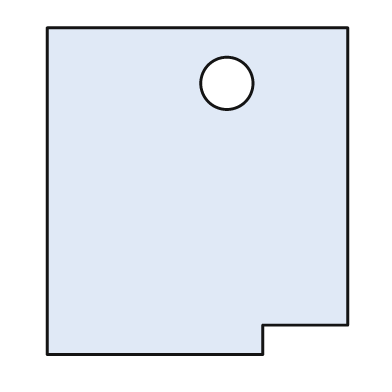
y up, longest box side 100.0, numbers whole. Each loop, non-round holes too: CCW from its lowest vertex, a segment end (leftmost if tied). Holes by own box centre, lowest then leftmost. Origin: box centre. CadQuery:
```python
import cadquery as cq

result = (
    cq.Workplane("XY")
    .moveTo(-46.0, -50.0)
    .lineTo(20.0, -50.0)
    .lineTo(20.0, -41.0)
    .lineTo(46.0, -41.0)
    .lineTo(46.0, 50.0)
    .lineTo(-46.0, 50.0)
    .close()
    .moveTo(9.0, 33.0)
    .circle(8.0)
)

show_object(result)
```